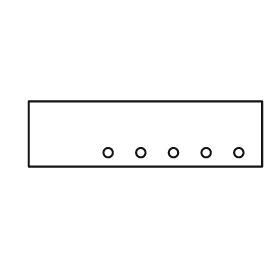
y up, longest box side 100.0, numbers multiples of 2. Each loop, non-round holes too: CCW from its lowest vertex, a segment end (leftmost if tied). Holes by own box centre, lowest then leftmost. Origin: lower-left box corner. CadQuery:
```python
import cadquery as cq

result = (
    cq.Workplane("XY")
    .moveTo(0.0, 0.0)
    .lineTo(100.0, 0.0)
    .lineTo(100.0, 28.0)
    .lineTo(0.0, 28.0)
    .close()
    .moveTo(34.0, 6.0)
    .circle(2.0)
    .moveTo(48.0, 6.0)
    .circle(2.0)
    .moveTo(62.0, 6.0)
    .circle(2.0)
    .moveTo(76.0, 6.0)
    .circle(2.0)
    .moveTo(90.0, 6.0)
    .circle(2.0)
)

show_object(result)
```